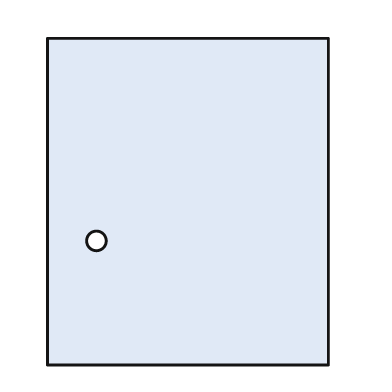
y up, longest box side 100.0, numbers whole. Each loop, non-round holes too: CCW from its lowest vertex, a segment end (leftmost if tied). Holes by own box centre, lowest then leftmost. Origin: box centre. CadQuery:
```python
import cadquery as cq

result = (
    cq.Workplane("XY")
    .moveTo(-43.0, -50.0)
    .lineTo(43.0, -50.0)
    .lineTo(43.0, 50.0)
    .lineTo(-43.0, 50.0)
    .close()
    .moveTo(-28.0, -12.0)
    .circle(3.0)
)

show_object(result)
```